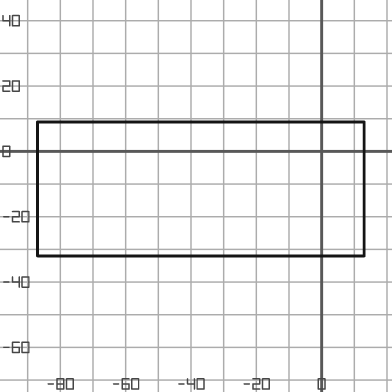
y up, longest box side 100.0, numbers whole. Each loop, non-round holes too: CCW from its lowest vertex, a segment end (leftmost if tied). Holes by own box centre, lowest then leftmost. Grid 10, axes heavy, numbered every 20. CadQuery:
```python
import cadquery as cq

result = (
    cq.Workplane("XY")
    .moveTo(-87.0, -32.0)
    .lineTo(13.0, -32.0)
    .lineTo(13.0, 9.0)
    .lineTo(-87.0, 9.0)
    .close()
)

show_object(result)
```